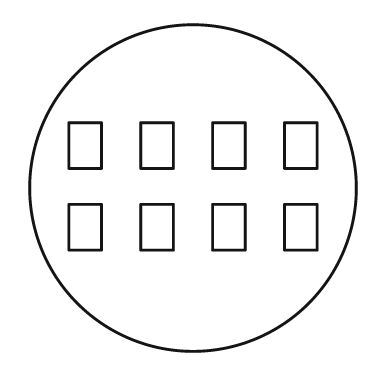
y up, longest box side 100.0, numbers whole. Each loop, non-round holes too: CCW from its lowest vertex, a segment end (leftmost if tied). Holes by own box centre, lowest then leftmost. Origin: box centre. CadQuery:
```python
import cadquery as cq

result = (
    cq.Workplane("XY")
    .moveTo(0.0, 0.0)
    .circle(50.0)
    .moveTo(-38.0, -19.0)
    .lineTo(-28.0, -19.0)
    .lineTo(-28.0, -5.0)
    .lineTo(-38.0, -5.0)
    .close()
    .moveTo(-16.0, -19.0)
    .lineTo(-6.0, -19.0)
    .lineTo(-6.0, -5.0)
    .lineTo(-16.0, -5.0)
    .close()
    .moveTo(6.0, -19.0)
    .lineTo(16.0, -19.0)
    .lineTo(16.0, -5.0)
    .lineTo(6.0, -5.0)
    .close()
    .moveTo(28.0, -19.0)
    .lineTo(38.0, -19.0)
    .lineTo(38.0, -5.0)
    .lineTo(28.0, -5.0)
    .close()
    .moveTo(-38.0, 6.0)
    .lineTo(-28.0, 6.0)
    .lineTo(-28.0, 20.0)
    .lineTo(-38.0, 20.0)
    .close()
    .moveTo(-16.0, 6.0)
    .lineTo(-6.0, 6.0)
    .lineTo(-6.0, 20.0)
    .lineTo(-16.0, 20.0)
    .close()
    .moveTo(6.0, 6.0)
    .lineTo(16.0, 6.0)
    .lineTo(16.0, 20.0)
    .lineTo(6.0, 20.0)
    .close()
    .moveTo(28.0, 6.0)
    .lineTo(38.0, 6.0)
    .lineTo(38.0, 20.0)
    .lineTo(28.0, 20.0)
    .close()
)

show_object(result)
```